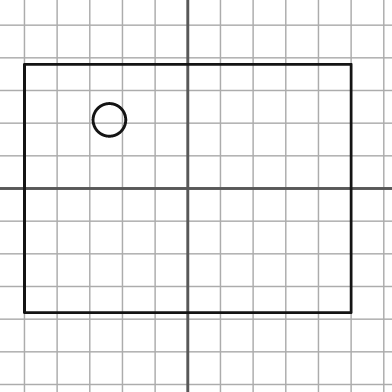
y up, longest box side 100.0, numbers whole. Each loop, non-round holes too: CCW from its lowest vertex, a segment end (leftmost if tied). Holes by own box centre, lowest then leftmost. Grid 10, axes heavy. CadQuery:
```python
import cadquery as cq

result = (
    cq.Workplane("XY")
    .moveTo(-50.0, -38.0)
    .lineTo(50.0, -38.0)
    .lineTo(50.0, 38.0)
    .lineTo(-50.0, 38.0)
    .close()
    .moveTo(-24.0, 21.0)
    .circle(5.0)
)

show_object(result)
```